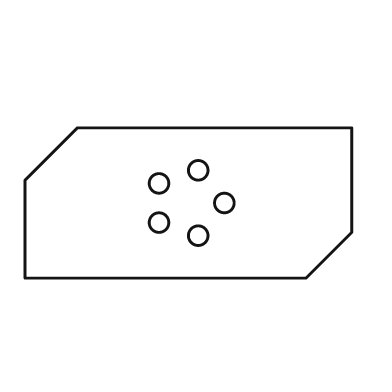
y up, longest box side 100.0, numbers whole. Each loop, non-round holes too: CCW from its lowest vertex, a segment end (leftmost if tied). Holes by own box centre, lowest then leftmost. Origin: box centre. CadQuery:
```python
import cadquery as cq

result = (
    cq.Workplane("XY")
    .moveTo(-50.0, -23.0)
    .lineTo(36.0, -23.0)
    .lineTo(50.0, -9.0)
    .lineTo(50.0, 23.0)
    .lineTo(-34.0, 23.0)
    .lineTo(-50.0, 7.0)
    .close()
    .moveTo(3.0, -10.0)
    .circle(3.0)
    .moveTo(-9.0, -6.0)
    .circle(3.0)
    .moveTo(11.0, 0.0)
    .circle(3.0)
    .moveTo(-9.0, 6.0)
    .circle(3.0)
    .moveTo(3.0, 10.0)
    .circle(3.0)
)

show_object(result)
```